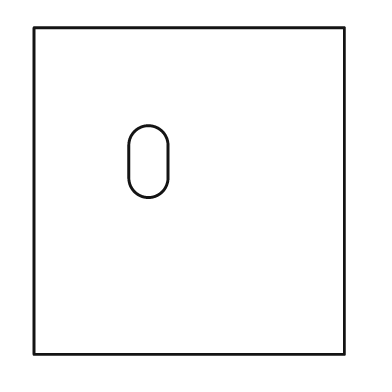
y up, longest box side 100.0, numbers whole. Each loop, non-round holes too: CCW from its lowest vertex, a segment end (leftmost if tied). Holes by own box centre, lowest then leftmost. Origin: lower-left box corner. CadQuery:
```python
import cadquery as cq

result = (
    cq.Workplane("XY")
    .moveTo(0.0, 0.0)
    .lineTo(95.0, 0.0)
    .lineTo(95.0, 100.0)
    .lineTo(0.0, 100.0)
    .close()
    .moveTo(29.0, 54.0)
    .threePointArc((35.0, 48.0), (41.0, 54.0))
    .lineTo(41.0, 64.0)
    .threePointArc((35.0, 70.0), (29.0, 64.0))
    .close()
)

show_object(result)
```